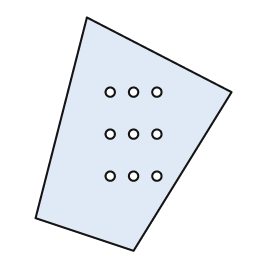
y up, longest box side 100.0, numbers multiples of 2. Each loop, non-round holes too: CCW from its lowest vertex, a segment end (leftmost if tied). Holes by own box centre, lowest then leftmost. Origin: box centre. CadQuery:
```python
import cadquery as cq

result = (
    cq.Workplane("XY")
    .moveTo(0.0, -50.0)
    .lineTo(42.0, 18.0)
    .lineTo(-20.0, 50.0)
    .lineTo(-42.0, -36.0)
    .close()
    .moveTo(-10.0, -18.0)
    .circle(2.0)
    .moveTo(0.0, -18.0)
    .circle(2.0)
    .moveTo(10.0, -18.0)
    .circle(2.0)
    .moveTo(-10.0, 0.0)
    .circle(2.0)
    .moveTo(0.0, 0.0)
    .circle(2.0)
    .moveTo(10.0, 0.0)
    .circle(2.0)
    .moveTo(-10.0, 18.0)
    .circle(2.0)
    .moveTo(0.0, 18.0)
    .circle(2.0)
    .moveTo(10.0, 18.0)
    .circle(2.0)
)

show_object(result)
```